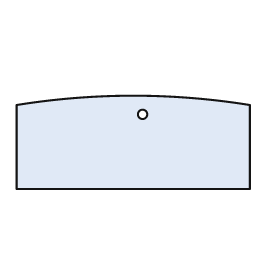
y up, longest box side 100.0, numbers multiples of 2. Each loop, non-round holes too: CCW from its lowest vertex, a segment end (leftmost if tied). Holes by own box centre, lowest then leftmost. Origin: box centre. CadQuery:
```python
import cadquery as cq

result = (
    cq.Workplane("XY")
    .moveTo(-50.0, -20.0)
    .lineTo(50.0, -20.0)
    .lineTo(50.0, 16.0)
    .threePointArc((0.0, 20.0), (-50.0, 16.0))
    .close()
    .moveTo(4.0, 12.0)
    .circle(2.0)
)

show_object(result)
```